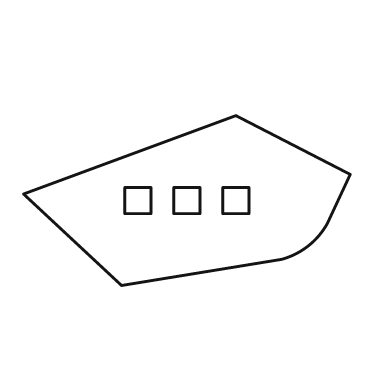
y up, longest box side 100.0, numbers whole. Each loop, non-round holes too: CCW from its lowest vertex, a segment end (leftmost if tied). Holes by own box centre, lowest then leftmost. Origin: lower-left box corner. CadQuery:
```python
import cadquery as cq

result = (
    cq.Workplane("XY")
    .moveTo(30.0, 0.0)
    .lineTo(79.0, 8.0)
    .threePointArc((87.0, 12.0), (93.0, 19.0))
    .lineTo(100.0, 34.0)
    .lineTo(65.0, 52.0)
    .lineTo(0.0, 28.0)
    .close()
    .moveTo(31.0, 22.0)
    .lineTo(39.0, 22.0)
    .lineTo(39.0, 30.0)
    .lineTo(31.0, 30.0)
    .close()
    .moveTo(46.0, 22.0)
    .lineTo(54.0, 22.0)
    .lineTo(54.0, 30.0)
    .lineTo(46.0, 30.0)
    .close()
    .moveTo(61.0, 22.0)
    .lineTo(69.0, 22.0)
    .lineTo(69.0, 30.0)
    .lineTo(61.0, 30.0)
    .close()
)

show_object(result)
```